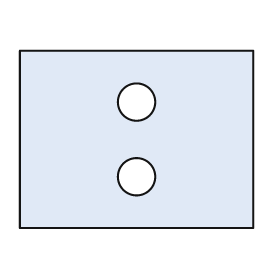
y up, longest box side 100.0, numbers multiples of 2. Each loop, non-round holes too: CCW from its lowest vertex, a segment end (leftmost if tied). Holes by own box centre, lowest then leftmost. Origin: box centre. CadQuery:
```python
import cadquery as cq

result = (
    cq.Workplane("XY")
    .moveTo(-50.0, -38.0)
    .lineTo(50.0, -38.0)
    .lineTo(50.0, 38.0)
    .lineTo(-50.0, 38.0)
    .close()
    .moveTo(0.0, -16.0)
    .circle(8.0)
    .moveTo(0.0, 16.0)
    .circle(8.0)
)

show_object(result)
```